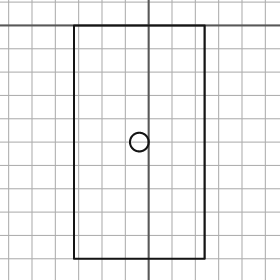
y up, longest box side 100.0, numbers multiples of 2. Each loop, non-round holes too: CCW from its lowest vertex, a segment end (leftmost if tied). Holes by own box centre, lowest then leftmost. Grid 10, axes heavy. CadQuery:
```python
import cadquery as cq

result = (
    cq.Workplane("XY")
    .moveTo(-32.0, -100.0)
    .lineTo(24.0, -100.0)
    .lineTo(24.0, 0.0)
    .lineTo(-32.0, 0.0)
    .close()
    .moveTo(-4.0, -50.0)
    .circle(4.0)
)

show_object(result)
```